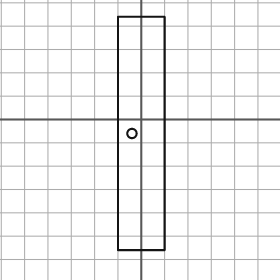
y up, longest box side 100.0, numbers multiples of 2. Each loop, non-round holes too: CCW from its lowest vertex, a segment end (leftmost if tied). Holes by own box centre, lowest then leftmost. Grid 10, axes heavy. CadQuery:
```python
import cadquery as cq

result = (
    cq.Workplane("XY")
    .moveTo(-10.0, -56.0)
    .lineTo(10.0, -56.0)
    .lineTo(10.0, 44.0)
    .lineTo(-10.0, 44.0)
    .close()
    .moveTo(-4.0, -6.0)
    .circle(2.0)
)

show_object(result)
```